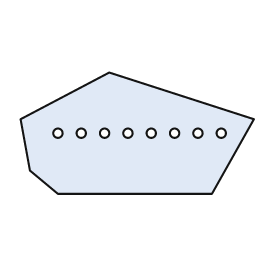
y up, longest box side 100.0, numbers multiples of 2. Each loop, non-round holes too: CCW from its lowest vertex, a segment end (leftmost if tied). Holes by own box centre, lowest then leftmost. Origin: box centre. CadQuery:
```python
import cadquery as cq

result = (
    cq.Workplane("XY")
    .moveTo(-34.0, -26.0)
    .lineTo(32.0, -26.0)
    .lineTo(50.0, 6.0)
    .lineTo(-12.0, 26.0)
    .lineTo(-50.0, 6.0)
    .lineTo(-46.0, -16.0)
    .close()
    .moveTo(-34.0, 0.0)
    .circle(2.0)
    .moveTo(-24.0, 0.0)
    .circle(2.0)
    .moveTo(-14.0, 0.0)
    .circle(2.0)
    .moveTo(-4.0, 0.0)
    .circle(2.0)
    .moveTo(6.0, 0.0)
    .circle(2.0)
    .moveTo(16.0, 0.0)
    .circle(2.0)
    .moveTo(26.0, 0.0)
    .circle(2.0)
    .moveTo(36.0, 0.0)
    .circle(2.0)
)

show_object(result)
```